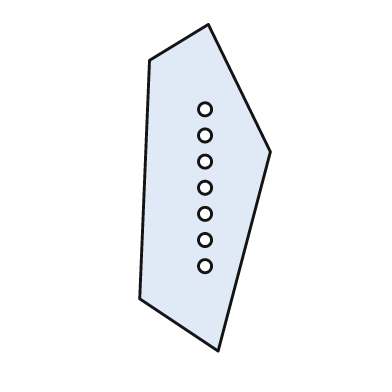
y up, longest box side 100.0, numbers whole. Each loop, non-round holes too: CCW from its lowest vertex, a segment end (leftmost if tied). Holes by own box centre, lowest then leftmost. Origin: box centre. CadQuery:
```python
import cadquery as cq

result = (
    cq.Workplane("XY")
    .moveTo(4.0, -50.0)
    .lineTo(20.0, 11.0)
    .lineTo(1.0, 50.0)
    .lineTo(-17.0, 39.0)
    .lineTo(-20.0, -34.0)
    .close()
    .moveTo(0.0, -24.0)
    .circle(2.0)
    .moveTo(0.0, -16.0)
    .circle(2.0)
    .moveTo(0.0, -8.0)
    .circle(2.0)
    .moveTo(0.0, 0.0)
    .circle(2.0)
    .moveTo(0.0, 8.0)
    .circle(2.0)
    .moveTo(0.0, 16.0)
    .circle(2.0)
    .moveTo(0.0, 24.0)
    .circle(2.0)
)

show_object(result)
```